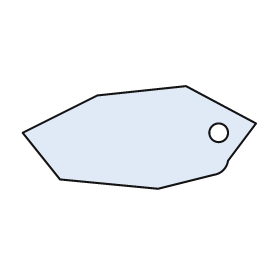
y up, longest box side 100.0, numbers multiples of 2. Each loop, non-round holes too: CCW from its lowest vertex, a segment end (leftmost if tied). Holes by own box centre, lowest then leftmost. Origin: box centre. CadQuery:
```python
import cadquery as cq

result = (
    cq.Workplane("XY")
    .moveTo(8.0, -22.0)
    .lineTo(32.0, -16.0)
    .threePointArc((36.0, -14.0), (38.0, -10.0))
    .lineTo(50.0, 6.0)
    .lineTo(20.0, 22.0)
    .lineTo(-18.0, 18.0)
    .lineTo(-50.0, 2.0)
    .lineTo(-34.0, -18.0)
    .close()
    .moveTo(34.0, 2.0)
    .circle(4.0)
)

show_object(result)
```